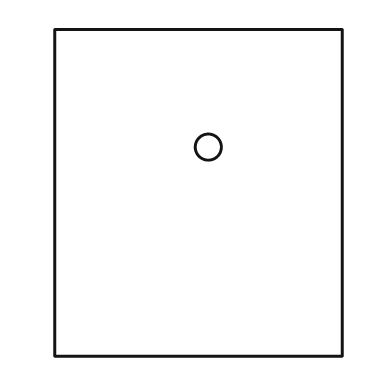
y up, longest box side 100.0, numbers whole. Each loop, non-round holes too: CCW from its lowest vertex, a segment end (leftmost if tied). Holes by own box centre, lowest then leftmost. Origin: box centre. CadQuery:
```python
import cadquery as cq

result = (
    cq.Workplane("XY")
    .moveTo(-44.0, -50.0)
    .lineTo(44.0, -50.0)
    .lineTo(44.0, 50.0)
    .lineTo(-44.0, 50.0)
    .close()
    .moveTo(3.0, 14.0)
    .circle(4.0)
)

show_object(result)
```